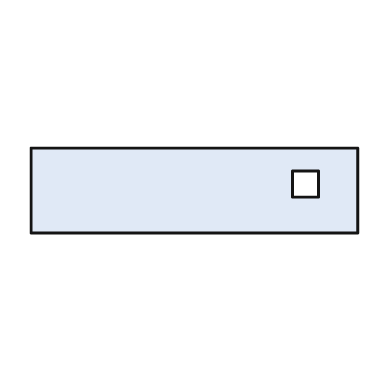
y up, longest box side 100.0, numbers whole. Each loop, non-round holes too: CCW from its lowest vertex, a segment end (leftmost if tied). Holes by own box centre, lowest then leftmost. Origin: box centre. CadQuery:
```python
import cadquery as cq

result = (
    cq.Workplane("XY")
    .moveTo(-50.0, -13.0)
    .lineTo(50.0, -13.0)
    .lineTo(50.0, 13.0)
    .lineTo(-50.0, 13.0)
    .close()
    .moveTo(30.0, -2.0)
    .lineTo(38.0, -2.0)
    .lineTo(38.0, 6.0)
    .lineTo(30.0, 6.0)
    .close()
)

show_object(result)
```